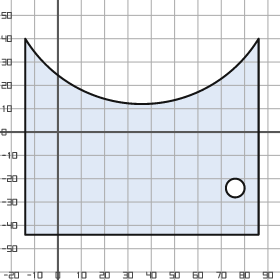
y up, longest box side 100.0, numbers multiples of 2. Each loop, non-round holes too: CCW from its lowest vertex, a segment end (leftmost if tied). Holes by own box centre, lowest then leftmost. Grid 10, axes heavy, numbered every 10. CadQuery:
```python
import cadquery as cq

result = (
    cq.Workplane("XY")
    .moveTo(-14.0, -44.0)
    .lineTo(86.0, -44.0)
    .lineTo(86.0, 40.0)
    .threePointArc((36.0, 12.0), (-14.0, 40.0))
    .close()
    .moveTo(76.0, -24.0)
    .circle(4.0)
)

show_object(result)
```